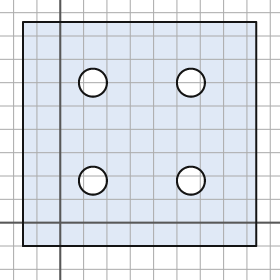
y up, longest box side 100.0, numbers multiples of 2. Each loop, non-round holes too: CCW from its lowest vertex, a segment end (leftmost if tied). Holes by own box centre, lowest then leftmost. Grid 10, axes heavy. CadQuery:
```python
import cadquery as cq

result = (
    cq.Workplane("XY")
    .moveTo(-16.0, -10.0)
    .lineTo(84.0, -10.0)
    .lineTo(84.0, 86.0)
    .lineTo(-16.0, 86.0)
    .close()
    .moveTo(14.0, 18.0)
    .circle(6.0)
    .moveTo(56.0, 18.0)
    .circle(6.0)
    .moveTo(14.0, 60.0)
    .circle(6.0)
    .moveTo(56.0, 60.0)
    .circle(6.0)
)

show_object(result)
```